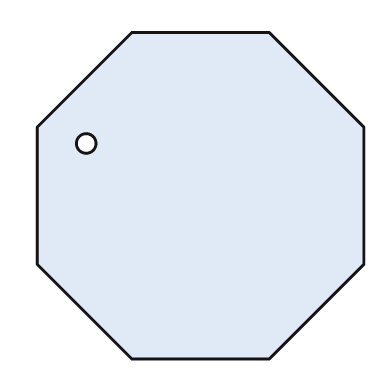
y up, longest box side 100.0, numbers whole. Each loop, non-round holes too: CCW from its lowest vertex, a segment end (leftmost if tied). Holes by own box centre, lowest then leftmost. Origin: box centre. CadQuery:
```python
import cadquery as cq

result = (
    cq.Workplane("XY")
    .moveTo(-21.0, -50.0)
    .lineTo(21.0, -50.0)
    .lineTo(50.0, -21.0)
    .lineTo(50.0, 21.0)
    .lineTo(21.0, 50.0)
    .lineTo(-21.0, 50.0)
    .lineTo(-50.0, 21.0)
    .lineTo(-50.0, -21.0)
    .close()
    .moveTo(-35.0, 16.0)
    .circle(3.0)
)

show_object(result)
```